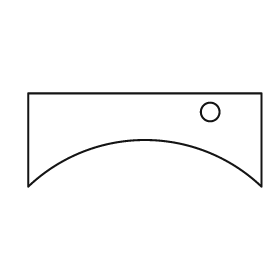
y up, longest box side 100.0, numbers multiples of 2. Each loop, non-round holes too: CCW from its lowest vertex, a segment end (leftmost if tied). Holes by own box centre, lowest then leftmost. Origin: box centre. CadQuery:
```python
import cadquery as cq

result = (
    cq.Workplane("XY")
    .moveTo(-50.0, -20.0)
    .threePointArc((0.0, 0.0), (50.0, -20.0))
    .lineTo(50.0, 20.0)
    .lineTo(-50.0, 20.0)
    .close()
    .moveTo(28.0, 12.0)
    .circle(4.0)
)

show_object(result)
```